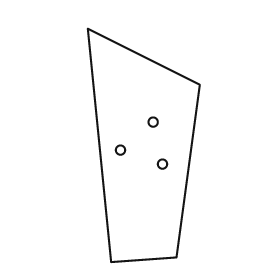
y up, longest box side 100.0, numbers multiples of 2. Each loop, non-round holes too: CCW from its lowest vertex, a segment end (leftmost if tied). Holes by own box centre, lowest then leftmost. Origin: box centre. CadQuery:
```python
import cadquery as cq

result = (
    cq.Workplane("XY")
    .moveTo(-14.0, -50.0)
    .lineTo(14.0, -48.0)
    .lineTo(24.0, 26.0)
    .lineTo(-24.0, 50.0)
    .close()
    .moveTo(8.0, -8.0)
    .circle(2.0)
    .moveTo(-10.0, -2.0)
    .circle(2.0)
    .moveTo(4.0, 10.0)
    .circle(2.0)
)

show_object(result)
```